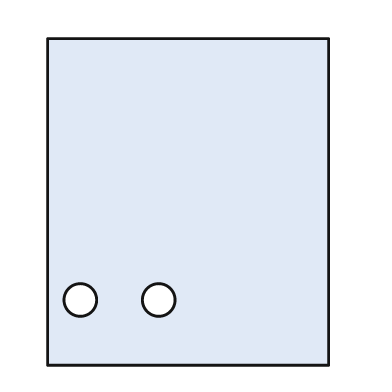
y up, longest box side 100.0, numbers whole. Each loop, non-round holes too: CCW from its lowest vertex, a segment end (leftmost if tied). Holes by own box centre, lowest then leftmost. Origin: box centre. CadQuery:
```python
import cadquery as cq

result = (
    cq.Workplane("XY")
    .moveTo(-43.0, -50.0)
    .lineTo(43.0, -50.0)
    .lineTo(43.0, 50.0)
    .lineTo(-43.0, 50.0)
    .close()
    .moveTo(-33.0, -30.0)
    .circle(5.0)
    .moveTo(-9.0, -30.0)
    .circle(5.0)
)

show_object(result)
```